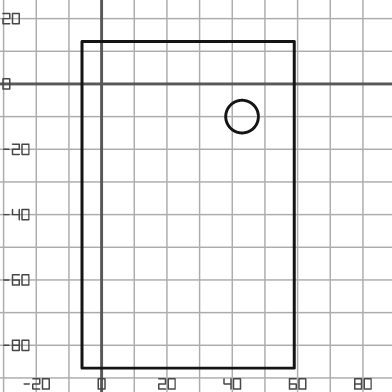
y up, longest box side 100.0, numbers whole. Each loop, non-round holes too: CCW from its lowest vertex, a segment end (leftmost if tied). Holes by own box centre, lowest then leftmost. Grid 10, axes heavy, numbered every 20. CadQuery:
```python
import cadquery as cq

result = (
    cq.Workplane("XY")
    .moveTo(-6.0, -87.0)
    .lineTo(59.0, -87.0)
    .lineTo(59.0, 13.0)
    .lineTo(-6.0, 13.0)
    .close()
    .moveTo(43.0, -10.0)
    .circle(5.0)
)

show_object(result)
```